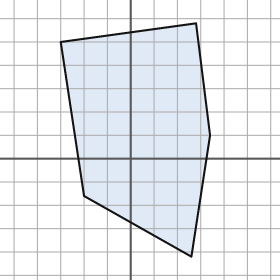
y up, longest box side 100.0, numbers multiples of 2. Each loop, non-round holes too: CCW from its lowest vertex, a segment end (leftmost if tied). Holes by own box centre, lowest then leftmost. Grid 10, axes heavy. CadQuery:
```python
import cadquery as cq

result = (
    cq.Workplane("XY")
    .moveTo(26.0, -42.0)
    .lineTo(34.0, 10.0)
    .lineTo(28.0, 58.0)
    .lineTo(-30.0, 50.0)
    .lineTo(-20.0, -16.0)
    .close()
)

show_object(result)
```